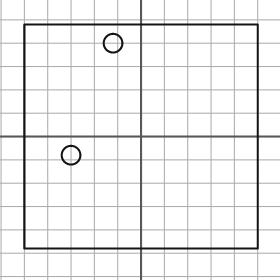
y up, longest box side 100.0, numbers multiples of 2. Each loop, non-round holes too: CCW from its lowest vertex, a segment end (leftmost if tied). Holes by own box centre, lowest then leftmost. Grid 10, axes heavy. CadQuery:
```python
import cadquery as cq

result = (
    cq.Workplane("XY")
    .moveTo(-50.0, -48.0)
    .lineTo(50.0, -48.0)
    .lineTo(50.0, 48.0)
    .lineTo(-50.0, 48.0)
    .close()
    .moveTo(-30.0, -8.0)
    .circle(4.0)
    .moveTo(-12.0, 40.0)
    .circle(4.0)
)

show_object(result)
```